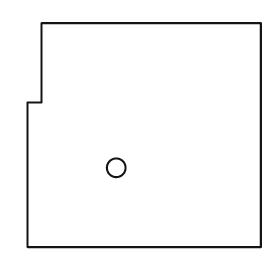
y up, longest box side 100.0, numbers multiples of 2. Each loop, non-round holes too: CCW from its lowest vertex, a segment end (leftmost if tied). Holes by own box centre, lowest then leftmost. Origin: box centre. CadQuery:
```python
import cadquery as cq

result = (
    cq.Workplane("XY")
    .moveTo(-50.0, -48.0)
    .lineTo(50.0, -48.0)
    .lineTo(50.0, 48.0)
    .lineTo(-44.0, 48.0)
    .lineTo(-44.0, 14.0)
    .lineTo(-50.0, 14.0)
    .close()
    .moveTo(-12.0, -14.0)
    .circle(4.0)
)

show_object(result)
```